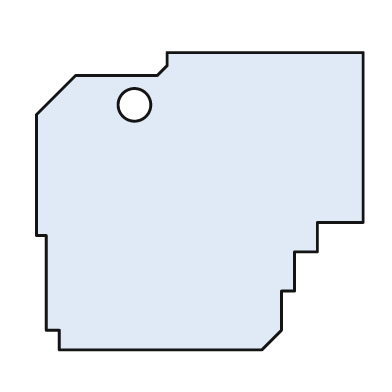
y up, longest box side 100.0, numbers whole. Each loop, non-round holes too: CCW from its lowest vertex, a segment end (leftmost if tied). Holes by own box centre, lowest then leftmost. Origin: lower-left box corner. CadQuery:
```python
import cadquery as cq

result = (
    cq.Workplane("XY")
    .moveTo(7.0, 0.0)
    .lineTo(69.0, 0.0)
    .lineTo(75.0, 6.0)
    .lineTo(75.0, 18.0)
    .lineTo(79.0, 18.0)
    .lineTo(79.0, 30.0)
    .lineTo(86.0, 30.0)
    .lineTo(86.0, 39.0)
    .lineTo(100.0, 39.0)
    .lineTo(100.0, 91.0)
    .lineTo(40.0, 91.0)
    .lineTo(40.0, 87.0)
    .lineTo(37.0, 84.0)
    .lineTo(12.0, 84.0)
    .lineTo(0.0, 72.0)
    .lineTo(0.0, 35.0)
    .lineTo(3.0, 35.0)
    .lineTo(3.0, 6.0)
    .lineTo(7.0, 6.0)
    .close()
    .moveTo(30.0, 75.0)
    .circle(5.0)
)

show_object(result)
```